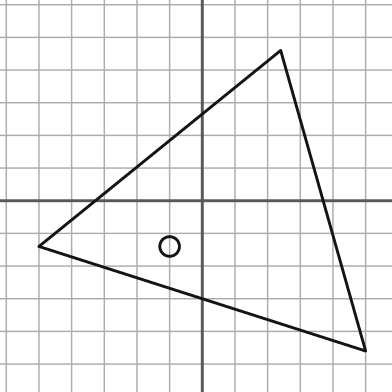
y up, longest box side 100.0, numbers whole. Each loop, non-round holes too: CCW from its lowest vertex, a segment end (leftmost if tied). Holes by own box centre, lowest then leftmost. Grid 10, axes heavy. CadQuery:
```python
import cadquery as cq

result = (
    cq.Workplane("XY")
    .moveTo(50.0, -46.0)
    .lineTo(24.0, 46.0)
    .lineTo(-50.0, -14.0)
    .close()
    .moveTo(-10.0, -14.0)
    .circle(3.0)
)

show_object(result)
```